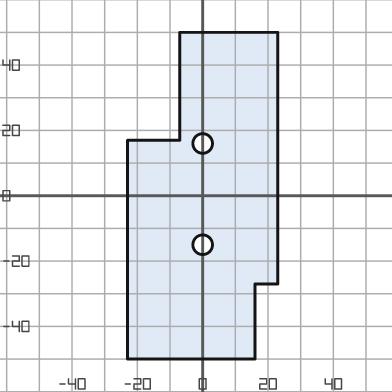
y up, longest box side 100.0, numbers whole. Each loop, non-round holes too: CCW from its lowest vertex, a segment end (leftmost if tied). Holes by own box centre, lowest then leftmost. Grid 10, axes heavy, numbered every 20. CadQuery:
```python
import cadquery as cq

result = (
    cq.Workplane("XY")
    .moveTo(-23.0, -50.0)
    .lineTo(16.0, -50.0)
    .lineTo(16.0, -27.0)
    .lineTo(23.0, -27.0)
    .lineTo(23.0, 50.0)
    .lineTo(-7.0, 50.0)
    .lineTo(-7.0, 17.0)
    .lineTo(-23.0, 17.0)
    .close()
    .moveTo(0.0, -15.0)
    .circle(3.0)
    .moveTo(0.0, 16.0)
    .circle(3.0)
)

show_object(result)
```